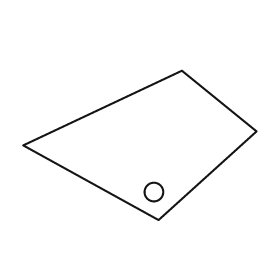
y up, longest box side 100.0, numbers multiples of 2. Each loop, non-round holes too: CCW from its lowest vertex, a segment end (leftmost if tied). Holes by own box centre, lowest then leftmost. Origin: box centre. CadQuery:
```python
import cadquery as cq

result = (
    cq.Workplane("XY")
    .moveTo(8.0, -32.0)
    .lineTo(50.0, 6.0)
    .lineTo(18.0, 32.0)
    .lineTo(-50.0, 0.0)
    .close()
    .moveTo(6.0, -20.0)
    .circle(4.0)
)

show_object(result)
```